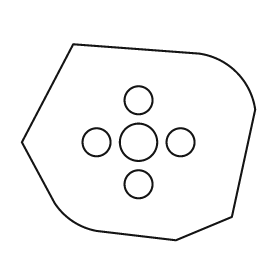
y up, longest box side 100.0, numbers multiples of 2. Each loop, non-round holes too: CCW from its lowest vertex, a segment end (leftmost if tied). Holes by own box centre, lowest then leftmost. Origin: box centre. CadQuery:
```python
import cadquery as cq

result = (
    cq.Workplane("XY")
    .moveTo(16.0, -42.0)
    .lineTo(40.0, -32.0)
    .lineTo(50.0, 14.0)
    .threePointArc((42.0, 30.0), (26.0, 38.0))
    .lineTo(-28.0, 42.0)
    .lineTo(-50.0, 0.0)
    .lineTo(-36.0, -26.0)
    .threePointArc((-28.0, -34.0), (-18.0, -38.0))
    .close()
    .moveTo(0.0, -18.0)
    .circle(6.0)
    .moveTo(-18.0, 0.0)
    .circle(6.0)
    .moveTo(0.0, 0.0)
    .circle(8.0)
    .moveTo(18.0, 0.0)
    .circle(6.0)
    .moveTo(0.0, 18.0)
    .circle(6.0)
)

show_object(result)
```